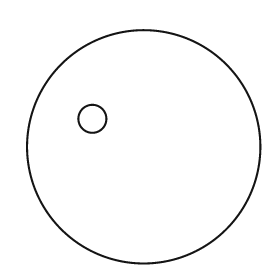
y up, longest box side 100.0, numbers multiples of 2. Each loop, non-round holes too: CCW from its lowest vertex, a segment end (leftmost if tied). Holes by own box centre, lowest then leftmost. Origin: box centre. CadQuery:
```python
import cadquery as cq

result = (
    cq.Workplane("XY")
    .moveTo(0.0, 0.0)
    .circle(50.0)
    .moveTo(-22.0, 12.0)
    .circle(6.0)
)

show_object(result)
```